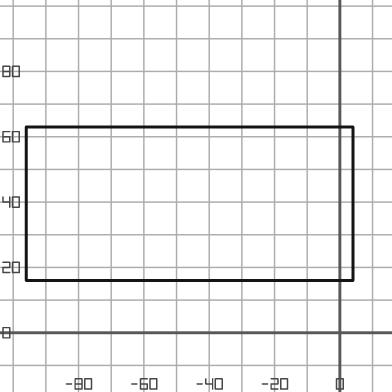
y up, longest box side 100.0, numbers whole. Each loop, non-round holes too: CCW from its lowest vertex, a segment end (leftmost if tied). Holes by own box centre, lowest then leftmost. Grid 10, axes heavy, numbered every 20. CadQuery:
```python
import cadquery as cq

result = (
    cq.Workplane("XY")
    .moveTo(-96.0, 16.0)
    .lineTo(4.0, 16.0)
    .lineTo(4.0, 63.0)
    .lineTo(-96.0, 63.0)
    .close()
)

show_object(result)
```